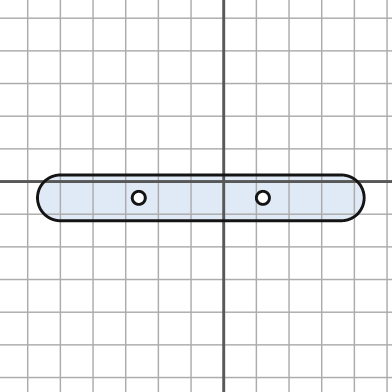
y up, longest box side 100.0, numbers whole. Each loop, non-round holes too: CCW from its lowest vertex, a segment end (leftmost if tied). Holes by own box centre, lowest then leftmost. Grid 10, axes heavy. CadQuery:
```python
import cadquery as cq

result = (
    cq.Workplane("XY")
    .moveTo(-50.0, -12.0)
    .lineTo(36.0, -12.0)
    .threePointArc((43.0, -5.0), (36.0, 2.0))
    .lineTo(-50.0, 2.0)
    .threePointArc((-57.0, -5.0), (-50.0, -12.0))
    .close()
    .moveTo(-26.0, -5.0)
    .circle(2.0)
    .moveTo(12.0, -5.0)
    .circle(2.0)
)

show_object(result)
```